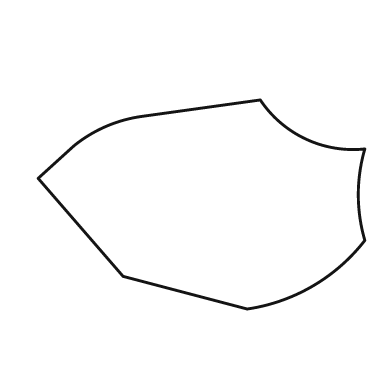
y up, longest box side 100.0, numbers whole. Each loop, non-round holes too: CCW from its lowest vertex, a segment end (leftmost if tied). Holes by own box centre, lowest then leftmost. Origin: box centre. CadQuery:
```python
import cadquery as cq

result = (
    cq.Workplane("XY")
    .moveTo(14.0, -32.0)
    .threePointArc((34.0, -25.0), (50.0, -11.0))
    .threePointArc((48.0, 3.0), (50.0, 17.0))
    .threePointArc((32.0, 20.0), (18.0, 32.0))
    .lineTo(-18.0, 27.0)
    .threePointArc((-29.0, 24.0), (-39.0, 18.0))
    .lineTo(-50.0, 8.0)
    .lineTo(-24.0, -22.0)
    .close()
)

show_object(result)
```